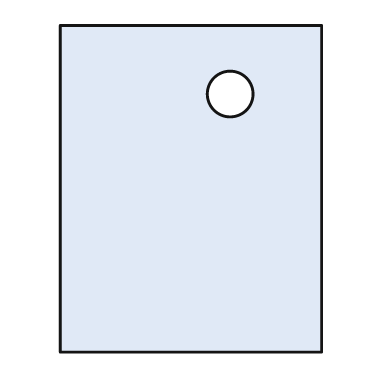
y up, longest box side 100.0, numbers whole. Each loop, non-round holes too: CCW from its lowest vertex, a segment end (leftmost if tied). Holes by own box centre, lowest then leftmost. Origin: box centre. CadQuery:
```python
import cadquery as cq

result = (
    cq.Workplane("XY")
    .moveTo(-40.0, -50.0)
    .lineTo(40.0, -50.0)
    .lineTo(40.0, 50.0)
    .lineTo(-40.0, 50.0)
    .close()
    .moveTo(12.0, 29.0)
    .circle(7.0)
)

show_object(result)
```